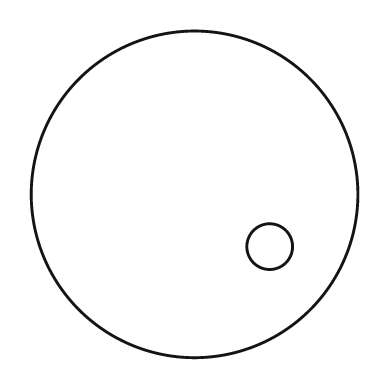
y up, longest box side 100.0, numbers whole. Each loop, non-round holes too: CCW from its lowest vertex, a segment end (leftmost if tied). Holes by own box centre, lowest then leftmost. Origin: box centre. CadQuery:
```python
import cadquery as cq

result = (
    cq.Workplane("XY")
    .moveTo(0.0, 0.0)
    .circle(50.0)
    .moveTo(23.0, -16.0)
    .circle(7.0)
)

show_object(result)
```